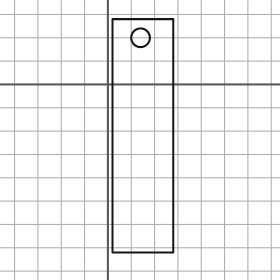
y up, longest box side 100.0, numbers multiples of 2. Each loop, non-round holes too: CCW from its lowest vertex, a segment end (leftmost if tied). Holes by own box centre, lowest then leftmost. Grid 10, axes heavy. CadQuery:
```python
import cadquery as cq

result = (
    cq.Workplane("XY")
    .moveTo(2.0, -72.0)
    .lineTo(28.0, -72.0)
    .lineTo(28.0, 28.0)
    .lineTo(2.0, 28.0)
    .close()
    .moveTo(14.0, 20.0)
    .circle(4.0)
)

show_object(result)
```